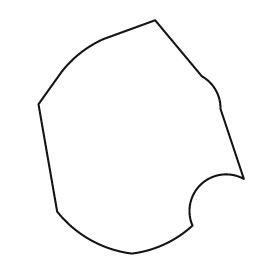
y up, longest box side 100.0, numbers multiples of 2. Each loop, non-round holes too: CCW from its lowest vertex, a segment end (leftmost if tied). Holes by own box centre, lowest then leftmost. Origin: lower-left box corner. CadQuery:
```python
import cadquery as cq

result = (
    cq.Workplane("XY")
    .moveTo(40.0, 0.0)
    .threePointArc((54.0, 4.0), (66.0, 12.0))
    .threePointArc((70.0, 30.0), (88.0, 32.0))
    .lineTo(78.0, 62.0)
    .threePointArc((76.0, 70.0), (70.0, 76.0))
    .lineTo(50.0, 100.0)
    .lineTo(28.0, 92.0)
    .threePointArc((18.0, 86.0), (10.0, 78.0))
    .lineTo(0.0, 64.0)
    .lineTo(8.0, 18.0)
    .threePointArc((22.0, 6.0), (40.0, 0.0))
    .close()
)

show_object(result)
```